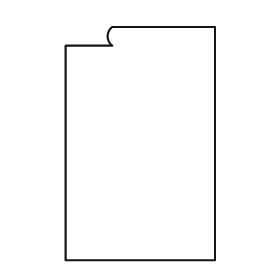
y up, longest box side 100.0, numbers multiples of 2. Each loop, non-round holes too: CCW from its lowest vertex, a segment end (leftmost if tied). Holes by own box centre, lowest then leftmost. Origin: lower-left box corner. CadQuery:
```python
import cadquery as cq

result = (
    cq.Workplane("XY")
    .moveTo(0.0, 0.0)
    .lineTo(64.0, 0.0)
    .lineTo(64.0, 100.0)
    .lineTo(20.0, 100.0)
    .threePointArc((18.0, 96.0), (20.0, 92.0))
    .lineTo(0.0, 92.0)
    .close()
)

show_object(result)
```